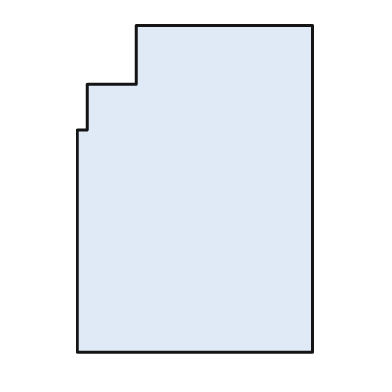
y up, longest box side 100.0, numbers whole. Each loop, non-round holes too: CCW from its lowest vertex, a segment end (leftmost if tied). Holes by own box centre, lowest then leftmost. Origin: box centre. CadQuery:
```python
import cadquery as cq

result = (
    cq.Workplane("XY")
    .moveTo(-36.0, -50.0)
    .lineTo(36.0, -50.0)
    .lineTo(36.0, 50.0)
    .lineTo(-18.0, 50.0)
    .lineTo(-18.0, 32.0)
    .lineTo(-33.0, 32.0)
    .lineTo(-33.0, 18.0)
    .lineTo(-36.0, 18.0)
    .close()
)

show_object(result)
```